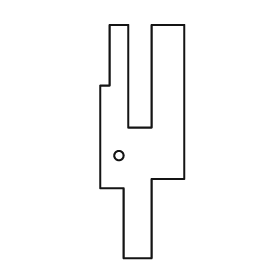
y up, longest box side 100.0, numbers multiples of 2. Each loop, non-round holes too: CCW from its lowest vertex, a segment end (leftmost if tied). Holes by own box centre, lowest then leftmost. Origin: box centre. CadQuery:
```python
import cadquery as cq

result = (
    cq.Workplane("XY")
    .moveTo(-8.0, -50.0)
    .lineTo(4.0, -50.0)
    .lineTo(4.0, -16.0)
    .lineTo(18.0, -16.0)
    .lineTo(18.0, 50.0)
    .lineTo(4.0, 50.0)
    .lineTo(4.0, 6.0)
    .lineTo(-6.0, 6.0)
    .lineTo(-6.0, 50.0)
    .lineTo(-14.0, 50.0)
    .lineTo(-14.0, 24.0)
    .lineTo(-18.0, 24.0)
    .lineTo(-18.0, -20.0)
    .lineTo(-8.0, -20.0)
    .close()
    .moveTo(-10.0, -6.0)
    .circle(2.0)
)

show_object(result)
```